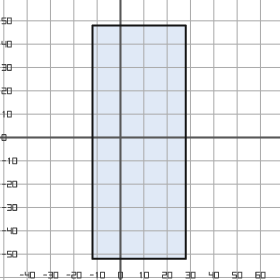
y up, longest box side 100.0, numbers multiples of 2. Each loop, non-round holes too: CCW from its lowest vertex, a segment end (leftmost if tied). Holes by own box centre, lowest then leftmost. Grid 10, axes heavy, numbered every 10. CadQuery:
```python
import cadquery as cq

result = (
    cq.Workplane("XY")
    .moveTo(-12.0, -52.0)
    .lineTo(28.0, -52.0)
    .lineTo(28.0, 48.0)
    .lineTo(-12.0, 48.0)
    .close()
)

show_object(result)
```